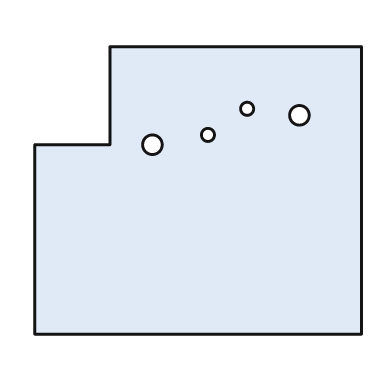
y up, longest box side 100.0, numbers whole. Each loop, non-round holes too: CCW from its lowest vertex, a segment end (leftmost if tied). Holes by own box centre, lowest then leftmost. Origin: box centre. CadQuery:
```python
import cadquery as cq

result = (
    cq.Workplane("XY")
    .moveTo(-50.0, -44.0)
    .lineTo(50.0, -44.0)
    .lineTo(50.0, 44.0)
    .lineTo(-27.0, 44.0)
    .lineTo(-27.0, 14.0)
    .lineTo(-50.0, 14.0)
    .close()
    .moveTo(-14.0, 14.0)
    .circle(3.0)
    .moveTo(3.0, 17.0)
    .circle(2.0)
    .moveTo(31.0, 23.0)
    .circle(3.0)
    .moveTo(15.0, 25.0)
    .circle(2.0)
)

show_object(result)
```